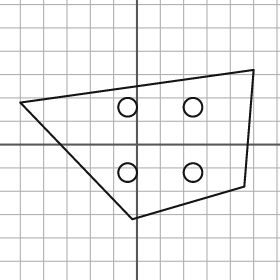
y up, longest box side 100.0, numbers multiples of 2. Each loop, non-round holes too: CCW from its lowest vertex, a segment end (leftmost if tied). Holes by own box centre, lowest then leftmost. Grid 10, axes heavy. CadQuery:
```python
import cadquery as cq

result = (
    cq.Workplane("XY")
    .moveTo(-2.0, -32.0)
    .lineTo(46.0, -18.0)
    .lineTo(50.0, 32.0)
    .lineTo(-50.0, 18.0)
    .close()
    .moveTo(-4.0, -12.0)
    .circle(4.0)
    .moveTo(24.0, -12.0)
    .circle(4.0)
    .moveTo(-4.0, 16.0)
    .circle(4.0)
    .moveTo(24.0, 16.0)
    .circle(4.0)
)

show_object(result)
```